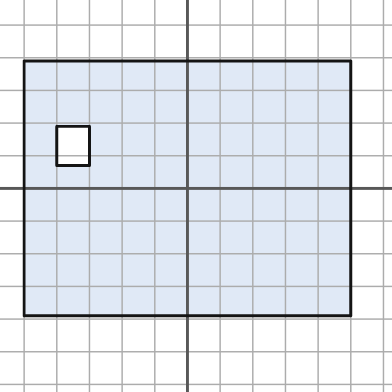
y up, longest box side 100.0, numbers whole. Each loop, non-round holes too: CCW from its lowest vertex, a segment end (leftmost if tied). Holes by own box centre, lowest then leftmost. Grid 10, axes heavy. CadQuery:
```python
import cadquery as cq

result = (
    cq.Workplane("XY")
    .moveTo(-50.0, -39.0)
    .lineTo(50.0, -39.0)
    .lineTo(50.0, 39.0)
    .lineTo(-50.0, 39.0)
    .close()
    .moveTo(-40.0, 7.0)
    .lineTo(-30.0, 7.0)
    .lineTo(-30.0, 19.0)
    .lineTo(-40.0, 19.0)
    .close()
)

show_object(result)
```